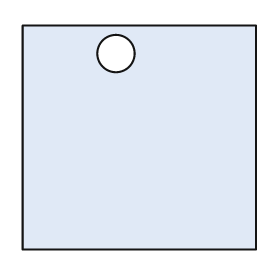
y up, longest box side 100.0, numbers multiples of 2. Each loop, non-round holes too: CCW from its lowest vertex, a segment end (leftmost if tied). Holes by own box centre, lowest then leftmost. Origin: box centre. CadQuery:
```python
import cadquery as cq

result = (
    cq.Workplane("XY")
    .moveTo(-50.0, -48.0)
    .lineTo(50.0, -48.0)
    .lineTo(50.0, 48.0)
    .lineTo(-50.0, 48.0)
    .close()
    .moveTo(-10.0, 36.0)
    .circle(8.0)
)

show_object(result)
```